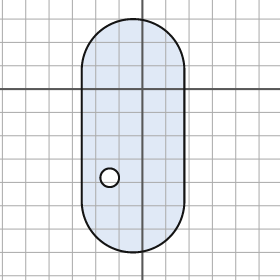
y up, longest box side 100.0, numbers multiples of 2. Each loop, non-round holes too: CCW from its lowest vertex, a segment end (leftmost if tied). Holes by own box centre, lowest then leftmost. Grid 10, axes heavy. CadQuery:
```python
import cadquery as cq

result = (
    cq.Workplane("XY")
    .moveTo(-26.0, -48.0)
    .threePointArc((-4.0, -70.0), (18.0, -48.0))
    .lineTo(18.0, 8.0)
    .threePointArc((-4.0, 30.0), (-26.0, 8.0))
    .close()
    .moveTo(-14.0, -38.0)
    .circle(4.0)
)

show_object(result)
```